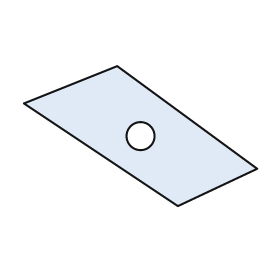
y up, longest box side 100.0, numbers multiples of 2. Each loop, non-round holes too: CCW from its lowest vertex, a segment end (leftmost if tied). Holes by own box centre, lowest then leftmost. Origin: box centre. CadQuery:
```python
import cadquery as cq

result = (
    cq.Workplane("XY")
    .moveTo(16.0, -30.0)
    .lineTo(50.0, -14.0)
    .lineTo(-10.0, 30.0)
    .lineTo(-50.0, 14.0)
    .close()
    .moveTo(0.0, 0.0)
    .circle(6.0)
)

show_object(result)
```